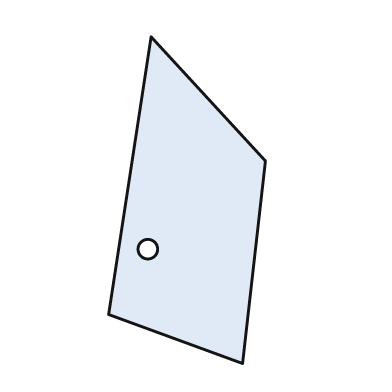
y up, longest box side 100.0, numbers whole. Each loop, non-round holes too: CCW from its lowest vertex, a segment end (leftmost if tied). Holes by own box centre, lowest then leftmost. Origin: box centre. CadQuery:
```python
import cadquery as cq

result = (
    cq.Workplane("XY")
    .moveTo(17.0, -50.0)
    .lineTo(24.0, 12.0)
    .lineTo(-11.0, 50.0)
    .lineTo(-24.0, -35.0)
    .close()
    .moveTo(-12.0, -15.0)
    .circle(3.0)
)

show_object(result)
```